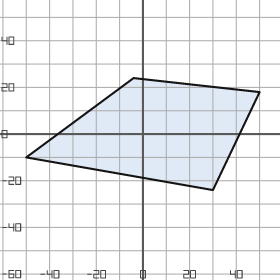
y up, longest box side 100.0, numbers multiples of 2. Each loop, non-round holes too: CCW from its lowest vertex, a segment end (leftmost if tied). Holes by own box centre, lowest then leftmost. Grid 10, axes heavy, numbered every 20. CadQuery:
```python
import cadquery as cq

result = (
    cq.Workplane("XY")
    .moveTo(30.0, -24.0)
    .lineTo(50.0, 18.0)
    .lineTo(-4.0, 24.0)
    .lineTo(-50.0, -10.0)
    .close()
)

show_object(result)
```